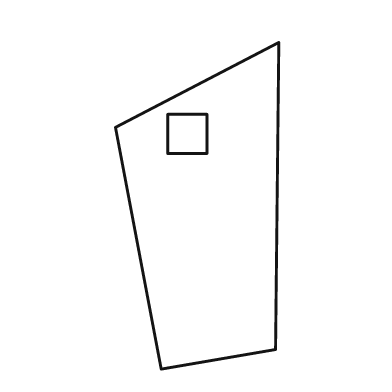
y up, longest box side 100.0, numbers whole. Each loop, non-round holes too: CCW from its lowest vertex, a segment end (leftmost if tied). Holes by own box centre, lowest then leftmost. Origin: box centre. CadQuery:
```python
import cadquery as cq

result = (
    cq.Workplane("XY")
    .moveTo(-11.0, -50.0)
    .lineTo(24.0, -44.0)
    .lineTo(25.0, 50.0)
    .lineTo(-25.0, 24.0)
    .close()
    .moveTo(-9.0, 16.0)
    .lineTo(3.0, 16.0)
    .lineTo(3.0, 28.0)
    .lineTo(-9.0, 28.0)
    .close()
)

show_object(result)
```